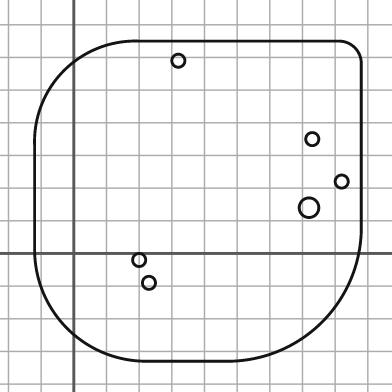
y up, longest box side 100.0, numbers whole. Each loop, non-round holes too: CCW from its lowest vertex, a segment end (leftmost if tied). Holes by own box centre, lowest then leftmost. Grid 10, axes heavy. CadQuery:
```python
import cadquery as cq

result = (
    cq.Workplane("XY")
    .moveTo(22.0, -33.0)
    .lineTo(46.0, -33.0)
    .threePointArc((76.0, -21.0), (88.0, 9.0))
    .lineTo(88.0, 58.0)
    .threePointArc((86.0, 63.0), (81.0, 65.0))
    .lineTo(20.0, 65.0)
    .threePointArc((-3.0, 56.0), (-12.0, 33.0))
    .lineTo(-12.0, 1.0)
    .threePointArc((-2.0, -23.0), (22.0, -33.0))
    .close()
    .moveTo(23.0, -9.0)
    .circle(2.0)
    .moveTo(20.0, -2.0)
    .circle(2.0)
    .moveTo(72.0, 14.0)
    .circle(3.0)
    .moveTo(82.0, 22.0)
    .circle(2.0)
    .moveTo(73.0, 35.0)
    .circle(2.0)
    .moveTo(32.0, 59.0)
    .circle(2.0)
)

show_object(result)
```